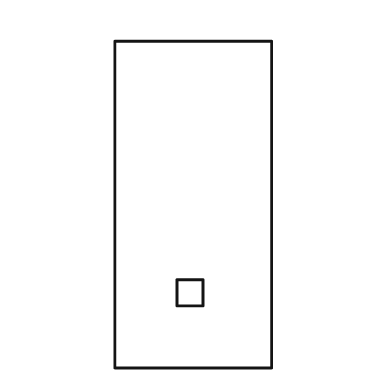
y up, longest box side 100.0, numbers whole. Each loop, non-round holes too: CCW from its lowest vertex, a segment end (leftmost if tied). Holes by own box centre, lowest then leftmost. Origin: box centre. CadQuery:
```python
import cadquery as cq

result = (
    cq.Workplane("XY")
    .moveTo(-24.0, -50.0)
    .lineTo(24.0, -50.0)
    .lineTo(24.0, 50.0)
    .lineTo(-24.0, 50.0)
    .close()
    .moveTo(-5.0, -31.0)
    .lineTo(3.0, -31.0)
    .lineTo(3.0, -23.0)
    .lineTo(-5.0, -23.0)
    .close()
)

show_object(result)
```